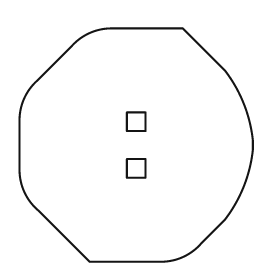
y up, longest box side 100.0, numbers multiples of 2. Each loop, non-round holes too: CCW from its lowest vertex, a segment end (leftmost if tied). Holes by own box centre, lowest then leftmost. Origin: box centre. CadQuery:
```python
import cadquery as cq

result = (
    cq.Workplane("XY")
    .moveTo(-20.0, -50.0)
    .lineTo(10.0, -50.0)
    .threePointArc((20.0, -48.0), (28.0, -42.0))
    .lineTo(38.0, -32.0)
    .threePointArc((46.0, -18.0), (50.0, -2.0))
    .lineTo(50.0, 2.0)
    .threePointArc((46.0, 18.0), (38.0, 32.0))
    .lineTo(20.0, 50.0)
    .lineTo(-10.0, 50.0)
    .threePointArc((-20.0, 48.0), (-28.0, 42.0))
    .lineTo(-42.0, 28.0)
    .threePointArc((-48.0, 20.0), (-50.0, 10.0))
    .lineTo(-50.0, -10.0)
    .threePointArc((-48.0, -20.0), (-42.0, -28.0))
    .close()
    .moveTo(-4.0, -14.0)
    .lineTo(4.0, -14.0)
    .lineTo(4.0, -6.0)
    .lineTo(-4.0, -6.0)
    .close()
    .moveTo(-4.0, 6.0)
    .lineTo(4.0, 6.0)
    .lineTo(4.0, 14.0)
    .lineTo(-4.0, 14.0)
    .close()
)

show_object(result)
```